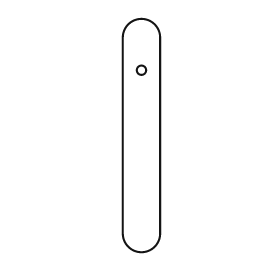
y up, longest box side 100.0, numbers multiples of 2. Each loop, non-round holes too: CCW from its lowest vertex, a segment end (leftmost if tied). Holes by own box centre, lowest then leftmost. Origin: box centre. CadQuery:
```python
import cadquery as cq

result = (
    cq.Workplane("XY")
    .moveTo(-8.0, -42.0)
    .threePointArc((0.0, -50.0), (8.0, -42.0))
    .lineTo(8.0, 42.0)
    .threePointArc((0.0, 50.0), (-8.0, 42.0))
    .close()
    .moveTo(0.0, 28.0)
    .circle(2.0)
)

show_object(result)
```